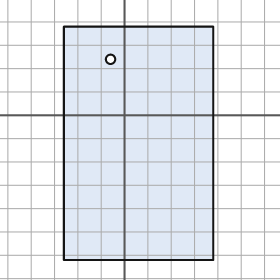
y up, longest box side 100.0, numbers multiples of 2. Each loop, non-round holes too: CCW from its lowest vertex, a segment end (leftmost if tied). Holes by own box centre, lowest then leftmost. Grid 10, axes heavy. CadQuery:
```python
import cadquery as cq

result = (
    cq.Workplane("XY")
    .moveTo(-26.0, -62.0)
    .lineTo(38.0, -62.0)
    .lineTo(38.0, 38.0)
    .lineTo(-26.0, 38.0)
    .close()
    .moveTo(-6.0, 24.0)
    .circle(2.0)
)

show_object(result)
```